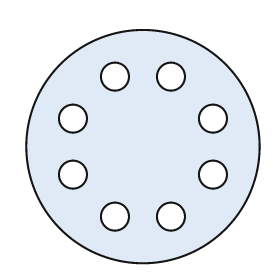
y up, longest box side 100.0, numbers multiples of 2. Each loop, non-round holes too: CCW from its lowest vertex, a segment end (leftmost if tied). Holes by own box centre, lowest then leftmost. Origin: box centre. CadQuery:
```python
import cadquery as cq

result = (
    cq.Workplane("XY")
    .moveTo(0.0, 0.0)
    .circle(50.0)
    .moveTo(-12.0, -30.0)
    .circle(6.0)
    .moveTo(12.0, -30.0)
    .circle(6.0)
    .moveTo(-30.0, -12.0)
    .circle(6.0)
    .moveTo(30.0, -12.0)
    .circle(6.0)
    .moveTo(-30.0, 12.0)
    .circle(6.0)
    .moveTo(30.0, 12.0)
    .circle(6.0)
    .moveTo(-12.0, 30.0)
    .circle(6.0)
    .moveTo(12.0, 30.0)
    .circle(6.0)
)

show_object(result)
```